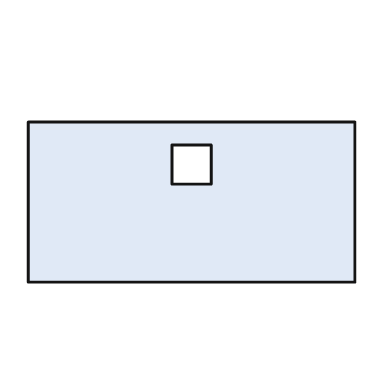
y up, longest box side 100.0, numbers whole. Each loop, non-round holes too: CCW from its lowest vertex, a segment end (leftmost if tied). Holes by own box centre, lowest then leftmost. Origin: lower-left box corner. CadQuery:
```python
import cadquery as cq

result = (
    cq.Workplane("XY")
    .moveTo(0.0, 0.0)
    .lineTo(100.0, 0.0)
    .lineTo(100.0, 49.0)
    .lineTo(0.0, 49.0)
    .close()
    .moveTo(44.0, 30.0)
    .lineTo(56.0, 30.0)
    .lineTo(56.0, 42.0)
    .lineTo(44.0, 42.0)
    .close()
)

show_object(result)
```